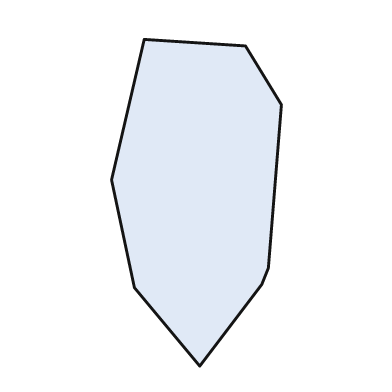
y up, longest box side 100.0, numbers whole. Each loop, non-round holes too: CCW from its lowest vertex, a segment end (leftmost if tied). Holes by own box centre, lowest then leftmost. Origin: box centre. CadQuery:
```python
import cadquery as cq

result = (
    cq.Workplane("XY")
    .moveTo(1.0, -50.0)
    .lineTo(20.0, -25.0)
    .lineTo(22.0, -20.0)
    .lineTo(26.0, 30.0)
    .lineTo(15.0, 48.0)
    .lineTo(-16.0, 50.0)
    .lineTo(-26.0, 7.0)
    .lineTo(-19.0, -26.0)
    .close()
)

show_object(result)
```